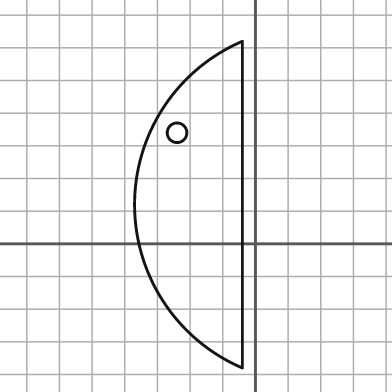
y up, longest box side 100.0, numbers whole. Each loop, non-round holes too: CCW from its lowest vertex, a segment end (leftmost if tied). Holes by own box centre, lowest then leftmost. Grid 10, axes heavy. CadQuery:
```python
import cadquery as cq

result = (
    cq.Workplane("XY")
    .moveTo(-4.0, -38.0)
    .lineTo(-4.0, 62.0)
    .threePointArc((-37.0, 12.0), (-4.0, -38.0))
    .close()
    .moveTo(-24.0, 34.0)
    .circle(3.0)
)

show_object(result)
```